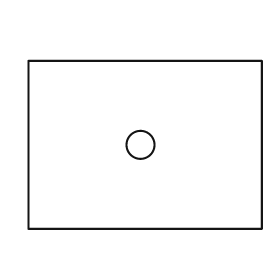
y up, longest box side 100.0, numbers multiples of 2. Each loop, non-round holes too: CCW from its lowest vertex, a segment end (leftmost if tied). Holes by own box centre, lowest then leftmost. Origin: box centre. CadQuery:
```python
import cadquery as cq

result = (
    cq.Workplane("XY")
    .moveTo(-50.0, -36.0)
    .lineTo(50.0, -36.0)
    .lineTo(50.0, 36.0)
    .lineTo(-50.0, 36.0)
    .close()
    .moveTo(-2.0, 0.0)
    .circle(6.0)
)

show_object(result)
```